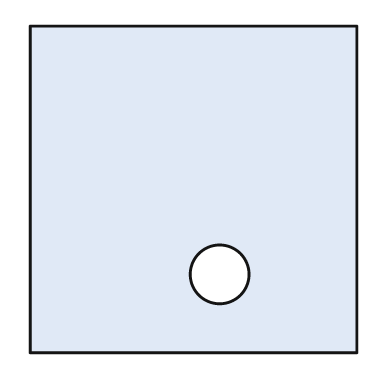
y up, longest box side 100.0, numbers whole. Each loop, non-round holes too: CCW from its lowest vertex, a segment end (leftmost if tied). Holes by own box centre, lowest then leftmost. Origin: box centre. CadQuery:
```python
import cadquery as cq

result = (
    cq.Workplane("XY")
    .moveTo(-50.0, -50.0)
    .lineTo(50.0, -50.0)
    .lineTo(50.0, 50.0)
    .lineTo(-50.0, 50.0)
    .close()
    .moveTo(8.0, -26.0)
    .circle(9.0)
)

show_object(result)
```